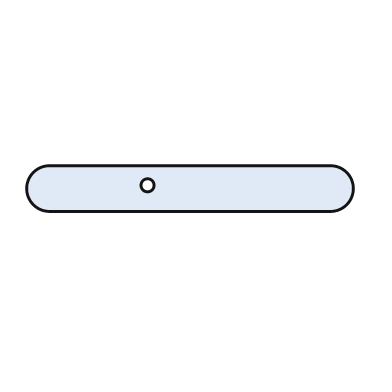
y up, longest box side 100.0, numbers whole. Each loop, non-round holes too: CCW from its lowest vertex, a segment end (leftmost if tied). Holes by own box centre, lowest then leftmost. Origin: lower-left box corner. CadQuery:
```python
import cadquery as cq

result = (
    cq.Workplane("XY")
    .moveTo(7.0, 0.0)
    .lineTo(93.0, 0.0)
    .threePointArc((100.0, 7.0), (93.0, 14.0))
    .lineTo(7.0, 14.0)
    .threePointArc((0.0, 7.0), (7.0, 0.0))
    .close()
    .moveTo(37.0, 8.0)
    .circle(2.0)
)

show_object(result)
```